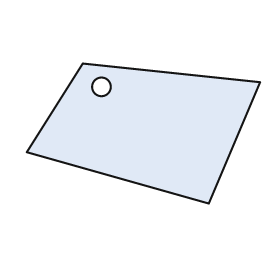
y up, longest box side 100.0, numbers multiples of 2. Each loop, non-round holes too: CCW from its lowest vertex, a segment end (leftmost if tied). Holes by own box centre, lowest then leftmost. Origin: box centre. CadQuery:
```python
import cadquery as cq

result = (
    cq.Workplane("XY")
    .moveTo(28.0, -30.0)
    .lineTo(50.0, 22.0)
    .lineTo(-26.0, 30.0)
    .lineTo(-50.0, -8.0)
    .close()
    .moveTo(-18.0, 20.0)
    .circle(4.0)
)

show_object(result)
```